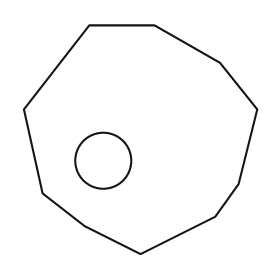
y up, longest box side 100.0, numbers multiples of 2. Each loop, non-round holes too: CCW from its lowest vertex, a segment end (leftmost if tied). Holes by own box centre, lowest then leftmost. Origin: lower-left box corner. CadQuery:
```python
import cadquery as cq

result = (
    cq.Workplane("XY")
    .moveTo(50.0, 0.0)
    .lineTo(82.0, 16.0)
    .lineTo(92.0, 30.0)
    .lineTo(100.0, 62.0)
    .lineTo(84.0, 82.0)
    .lineTo(56.0, 98.0)
    .lineTo(28.0, 98.0)
    .lineTo(0.0, 62.0)
    .lineTo(8.0, 26.0)
    .lineTo(26.0, 12.0)
    .close()
    .moveTo(34.0, 40.0)
    .circle(12.0)
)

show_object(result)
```